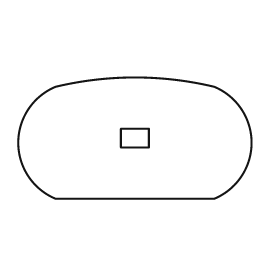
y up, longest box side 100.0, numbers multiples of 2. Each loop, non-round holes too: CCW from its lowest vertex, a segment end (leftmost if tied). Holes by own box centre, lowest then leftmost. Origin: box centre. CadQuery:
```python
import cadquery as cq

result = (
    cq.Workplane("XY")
    .moveTo(-34.0, -26.0)
    .lineTo(34.0, -26.0)
    .threePointArc((50.0, -2.0), (34.0, 22.0))
    .threePointArc((0.0, 26.0), (-34.0, 22.0))
    .threePointArc((-50.0, -2.0), (-34.0, -26.0))
    .close()
    .moveTo(-6.0, -4.0)
    .lineTo(6.0, -4.0)
    .lineTo(6.0, 4.0)
    .lineTo(-6.0, 4.0)
    .close()
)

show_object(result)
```